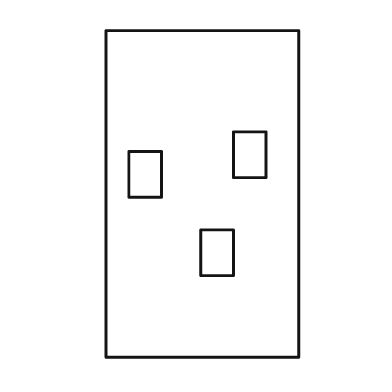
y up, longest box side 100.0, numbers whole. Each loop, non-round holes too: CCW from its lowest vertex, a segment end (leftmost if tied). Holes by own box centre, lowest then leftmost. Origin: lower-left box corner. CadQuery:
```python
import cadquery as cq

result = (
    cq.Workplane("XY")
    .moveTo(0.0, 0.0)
    .lineTo(59.0, 0.0)
    .lineTo(59.0, 100.0)
    .lineTo(0.0, 100.0)
    .close()
    .moveTo(29.0, 25.0)
    .lineTo(39.0, 25.0)
    .lineTo(39.0, 39.0)
    .lineTo(29.0, 39.0)
    .close()
    .moveTo(7.0, 49.0)
    .lineTo(17.0, 49.0)
    .lineTo(17.0, 63.0)
    .lineTo(7.0, 63.0)
    .close()
    .moveTo(39.0, 55.0)
    .lineTo(49.0, 55.0)
    .lineTo(49.0, 69.0)
    .lineTo(39.0, 69.0)
    .close()
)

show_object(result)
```